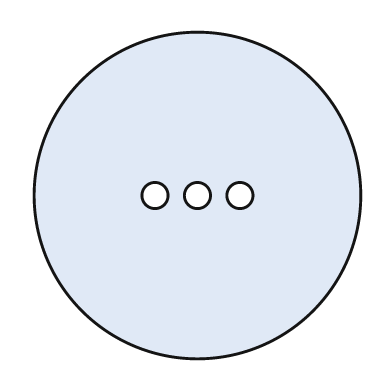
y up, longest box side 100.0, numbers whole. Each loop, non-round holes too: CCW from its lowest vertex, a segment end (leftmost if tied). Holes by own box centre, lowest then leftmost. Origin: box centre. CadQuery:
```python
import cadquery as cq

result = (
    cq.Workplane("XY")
    .moveTo(0.0, 0.0)
    .circle(50.0)
    .moveTo(-13.0, 0.0)
    .circle(4.0)
    .moveTo(0.0, 0.0)
    .circle(4.0)
    .moveTo(13.0, 0.0)
    .circle(4.0)
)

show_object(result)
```